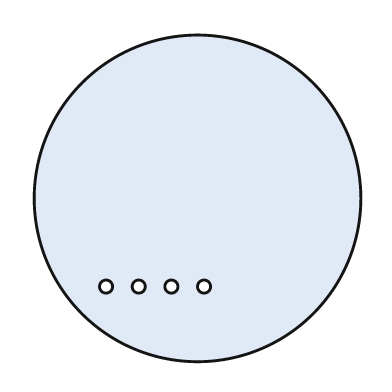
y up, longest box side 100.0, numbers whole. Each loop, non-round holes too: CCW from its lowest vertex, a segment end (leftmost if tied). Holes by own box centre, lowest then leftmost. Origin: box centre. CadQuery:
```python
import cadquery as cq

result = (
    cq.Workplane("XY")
    .moveTo(0.0, 0.0)
    .circle(50.0)
    .moveTo(-28.0, -27.0)
    .circle(2.0)
    .moveTo(-18.0, -27.0)
    .circle(2.0)
    .moveTo(-8.0, -27.0)
    .circle(2.0)
    .moveTo(2.0, -27.0)
    .circle(2.0)
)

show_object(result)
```